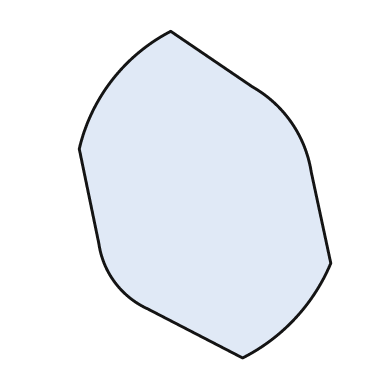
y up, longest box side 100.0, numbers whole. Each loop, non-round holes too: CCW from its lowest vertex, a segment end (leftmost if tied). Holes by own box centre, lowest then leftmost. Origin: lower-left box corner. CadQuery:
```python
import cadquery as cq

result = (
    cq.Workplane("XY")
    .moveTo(50.0, 0.0)
    .threePointArc((66.0, 12.0), (77.0, 29.0))
    .lineTo(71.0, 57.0)
    .threePointArc((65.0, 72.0), (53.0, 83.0))
    .lineTo(28.0, 100.0)
    .threePointArc((10.0, 85.0), (0.0, 64.0))
    .lineTo(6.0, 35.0)
    .threePointArc((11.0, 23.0), (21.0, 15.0))
    .close()
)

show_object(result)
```